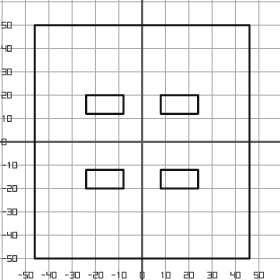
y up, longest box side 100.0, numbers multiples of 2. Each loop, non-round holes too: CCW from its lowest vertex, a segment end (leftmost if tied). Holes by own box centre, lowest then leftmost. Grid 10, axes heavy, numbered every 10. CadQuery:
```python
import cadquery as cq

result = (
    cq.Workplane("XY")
    .moveTo(-46.0, -50.0)
    .lineTo(46.0, -50.0)
    .lineTo(46.0, 50.0)
    .lineTo(-46.0, 50.0)
    .close()
    .moveTo(-24.0, -20.0)
    .lineTo(-8.0, -20.0)
    .lineTo(-8.0, -12.0)
    .lineTo(-24.0, -12.0)
    .close()
    .moveTo(8.0, -20.0)
    .lineTo(24.0, -20.0)
    .lineTo(24.0, -12.0)
    .lineTo(8.0, -12.0)
    .close()
    .moveTo(-24.0, 12.0)
    .lineTo(-8.0, 12.0)
    .lineTo(-8.0, 20.0)
    .lineTo(-24.0, 20.0)
    .close()
    .moveTo(8.0, 12.0)
    .lineTo(24.0, 12.0)
    .lineTo(24.0, 20.0)
    .lineTo(8.0, 20.0)
    .close()
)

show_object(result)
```